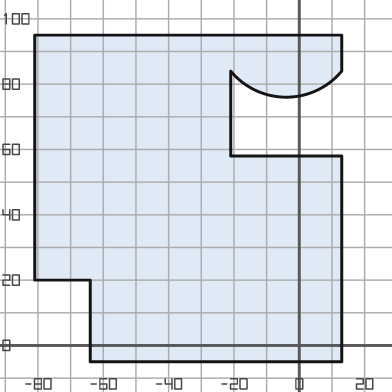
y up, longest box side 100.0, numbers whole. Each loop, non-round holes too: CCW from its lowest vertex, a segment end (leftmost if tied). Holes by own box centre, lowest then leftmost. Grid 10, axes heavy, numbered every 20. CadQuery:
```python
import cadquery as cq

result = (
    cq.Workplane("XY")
    .moveTo(-64.0, -5.0)
    .lineTo(13.0, -5.0)
    .lineTo(13.0, 58.0)
    .lineTo(-21.0, 58.0)
    .lineTo(-21.0, 84.0)
    .threePointArc((-4.0, 76.0), (13.0, 84.0))
    .lineTo(13.0, 95.0)
    .lineTo(-81.0, 95.0)
    .lineTo(-81.0, 20.0)
    .lineTo(-64.0, 20.0)
    .close()
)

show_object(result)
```